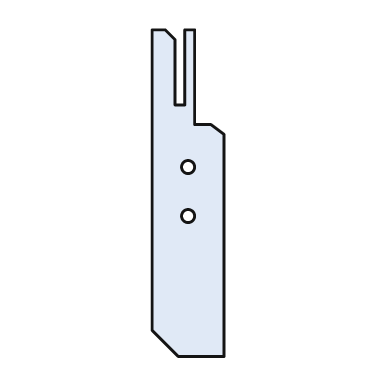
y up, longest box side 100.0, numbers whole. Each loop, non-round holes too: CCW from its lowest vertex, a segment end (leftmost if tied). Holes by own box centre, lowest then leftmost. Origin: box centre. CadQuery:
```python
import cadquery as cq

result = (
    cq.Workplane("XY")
    .moveTo(-3.0, -50.0)
    .lineTo(11.0, -50.0)
    .lineTo(11.0, 18.0)
    .lineTo(7.0, 21.0)
    .lineTo(2.0, 21.0)
    .lineTo(2.0, 50.0)
    .lineTo(-1.0, 50.0)
    .lineTo(-1.0, 27.0)
    .lineTo(-4.0, 27.0)
    .lineTo(-4.0, 47.0)
    .lineTo(-7.0, 50.0)
    .lineTo(-11.0, 50.0)
    .lineTo(-11.0, -42.0)
    .close()
    .moveTo(0.0, -7.0)
    .circle(2.0)
    .moveTo(0.0, 8.0)
    .circle(2.0)
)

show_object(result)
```